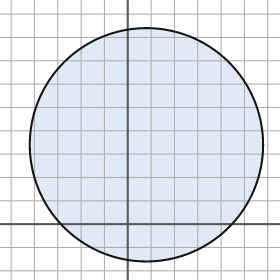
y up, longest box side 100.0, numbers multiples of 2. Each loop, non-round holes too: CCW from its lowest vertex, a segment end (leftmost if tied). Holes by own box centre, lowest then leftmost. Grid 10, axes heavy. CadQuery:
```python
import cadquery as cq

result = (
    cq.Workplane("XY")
    .moveTo(8.0, 34.0)
    .circle(50.0)
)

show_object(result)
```